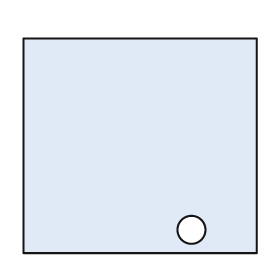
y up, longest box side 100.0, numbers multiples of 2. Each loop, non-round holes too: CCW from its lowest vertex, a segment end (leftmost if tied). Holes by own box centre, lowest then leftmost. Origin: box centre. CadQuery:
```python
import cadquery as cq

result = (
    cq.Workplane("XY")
    .moveTo(-50.0, -46.0)
    .lineTo(50.0, -46.0)
    .lineTo(50.0, 46.0)
    .lineTo(-50.0, 46.0)
    .close()
    .moveTo(22.0, -36.0)
    .circle(6.0)
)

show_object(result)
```